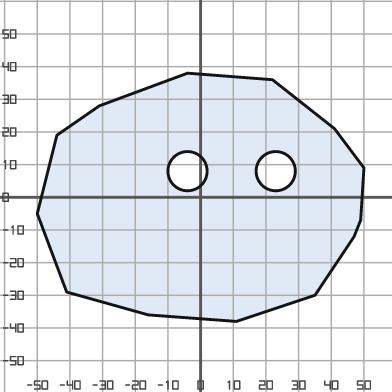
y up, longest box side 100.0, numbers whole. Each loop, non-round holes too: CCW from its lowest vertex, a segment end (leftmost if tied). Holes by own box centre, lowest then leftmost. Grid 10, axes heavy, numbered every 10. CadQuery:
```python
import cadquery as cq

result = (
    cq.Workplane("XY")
    .moveTo(11.0, -38.0)
    .lineTo(35.0, -30.0)
    .lineTo(47.0, -12.0)
    .lineTo(49.0, -7.0)
    .lineTo(50.0, 9.0)
    .lineTo(41.0, 21.0)
    .lineTo(22.0, 36.0)
    .lineTo(-4.0, 38.0)
    .lineTo(-31.0, 28.0)
    .lineTo(-44.0, 19.0)
    .lineTo(-50.0, -5.0)
    .lineTo(-41.0, -29.0)
    .lineTo(-16.0, -36.0)
    .close()
    .moveTo(-4.0, 8.0)
    .circle(6.0)
    .moveTo(23.0, 8.0)
    .circle(6.0)
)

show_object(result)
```